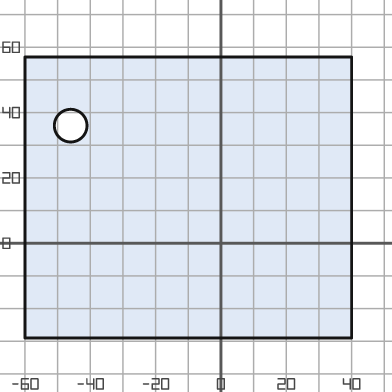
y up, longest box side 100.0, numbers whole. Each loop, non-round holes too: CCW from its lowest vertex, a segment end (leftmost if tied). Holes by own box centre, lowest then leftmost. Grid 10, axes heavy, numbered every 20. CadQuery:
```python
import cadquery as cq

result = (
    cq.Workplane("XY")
    .moveTo(-60.0, -29.0)
    .lineTo(40.0, -29.0)
    .lineTo(40.0, 57.0)
    .lineTo(-60.0, 57.0)
    .close()
    .moveTo(-46.0, 36.0)
    .circle(5.0)
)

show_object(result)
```